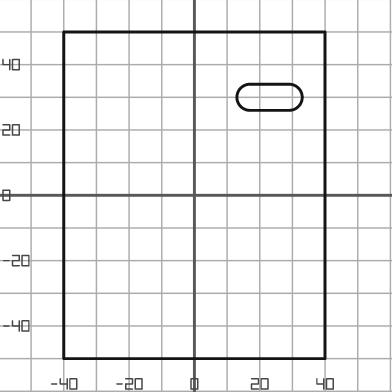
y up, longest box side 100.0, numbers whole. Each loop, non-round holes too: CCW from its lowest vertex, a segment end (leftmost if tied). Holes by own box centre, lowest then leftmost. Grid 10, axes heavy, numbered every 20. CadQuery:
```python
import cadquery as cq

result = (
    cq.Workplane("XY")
    .moveTo(-40.0, -50.0)
    .lineTo(40.0, -50.0)
    .lineTo(40.0, 50.0)
    .lineTo(-40.0, 50.0)
    .close()
    .moveTo(17.0, 26.0)
    .lineTo(29.0, 26.0)
    .threePointArc((33.0, 30.0), (29.0, 34.0))
    .lineTo(17.0, 34.0)
    .threePointArc((13.0, 30.0), (17.0, 26.0))
    .close()
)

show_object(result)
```